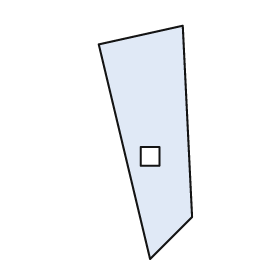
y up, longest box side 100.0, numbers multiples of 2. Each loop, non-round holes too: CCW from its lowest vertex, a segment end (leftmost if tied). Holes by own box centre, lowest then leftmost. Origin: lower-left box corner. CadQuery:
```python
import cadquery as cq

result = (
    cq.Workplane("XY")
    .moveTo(22.0, 0.0)
    .lineTo(40.0, 18.0)
    .lineTo(36.0, 100.0)
    .lineTo(0.0, 92.0)
    .close()
    .moveTo(18.0, 40.0)
    .lineTo(26.0, 40.0)
    .lineTo(26.0, 48.0)
    .lineTo(18.0, 48.0)
    .close()
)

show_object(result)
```